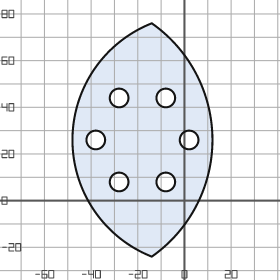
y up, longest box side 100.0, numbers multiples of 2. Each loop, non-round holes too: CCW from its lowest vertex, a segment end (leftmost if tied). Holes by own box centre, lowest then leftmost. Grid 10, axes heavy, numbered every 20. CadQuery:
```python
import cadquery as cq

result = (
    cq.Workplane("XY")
    .moveTo(-14.0, -24.0)
    .threePointArc((12.0, 26.0), (-14.0, 76.0))
    .threePointArc((-48.0, 26.0), (-14.0, -24.0))
    .close()
    .moveTo(-28.0, 8.0)
    .circle(4.0)
    .moveTo(-8.0, 8.0)
    .circle(4.0)
    .moveTo(-38.0, 26.0)
    .circle(4.0)
    .moveTo(2.0, 26.0)
    .circle(4.0)
    .moveTo(-28.0, 44.0)
    .circle(4.0)
    .moveTo(-8.0, 44.0)
    .circle(4.0)
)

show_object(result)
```